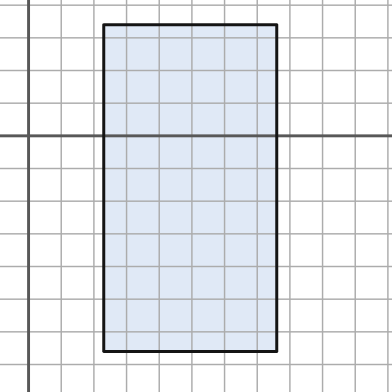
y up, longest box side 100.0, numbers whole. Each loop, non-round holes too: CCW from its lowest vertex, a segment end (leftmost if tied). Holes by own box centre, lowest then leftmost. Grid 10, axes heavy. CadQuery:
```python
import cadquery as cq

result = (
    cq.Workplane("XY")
    .moveTo(23.0, -66.0)
    .lineTo(76.0, -66.0)
    .lineTo(76.0, 34.0)
    .lineTo(23.0, 34.0)
    .close()
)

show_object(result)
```